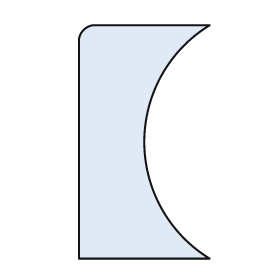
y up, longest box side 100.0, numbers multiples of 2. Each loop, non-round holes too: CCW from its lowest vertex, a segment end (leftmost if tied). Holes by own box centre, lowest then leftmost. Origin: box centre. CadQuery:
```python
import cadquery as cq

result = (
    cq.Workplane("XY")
    .moveTo(-28.0, -50.0)
    .lineTo(28.0, -50.0)
    .threePointArc((0.0, 0.0), (28.0, 50.0))
    .lineTo(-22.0, 50.0)
    .threePointArc((-26.0, 48.0), (-28.0, 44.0))
    .close()
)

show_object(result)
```